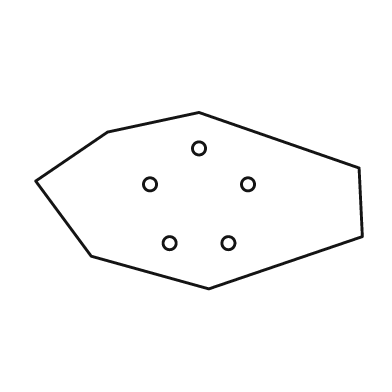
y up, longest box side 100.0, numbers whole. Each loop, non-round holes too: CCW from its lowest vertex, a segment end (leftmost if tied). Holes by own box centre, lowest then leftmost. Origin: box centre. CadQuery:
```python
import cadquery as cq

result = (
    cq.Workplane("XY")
    .moveTo(3.0, -27.0)
    .lineTo(50.0, -11.0)
    .lineTo(49.0, 10.0)
    .lineTo(0.0, 27.0)
    .lineTo(-28.0, 21.0)
    .lineTo(-50.0, 6.0)
    .lineTo(-33.0, -17.0)
    .close()
    .moveTo(-9.0, -13.0)
    .circle(2.0)
    .moveTo(9.0, -13.0)
    .circle(2.0)
    .moveTo(-15.0, 5.0)
    .circle(2.0)
    .moveTo(15.0, 5.0)
    .circle(2.0)
    .moveTo(0.0, 16.0)
    .circle(2.0)
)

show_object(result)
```